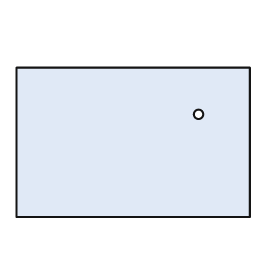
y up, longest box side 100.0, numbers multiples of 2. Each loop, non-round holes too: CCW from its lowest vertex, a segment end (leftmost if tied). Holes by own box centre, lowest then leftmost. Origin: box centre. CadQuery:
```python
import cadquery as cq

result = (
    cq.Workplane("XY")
    .moveTo(-50.0, -32.0)
    .lineTo(50.0, -32.0)
    .lineTo(50.0, 32.0)
    .lineTo(-50.0, 32.0)
    .close()
    .moveTo(28.0, 12.0)
    .circle(2.0)
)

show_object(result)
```